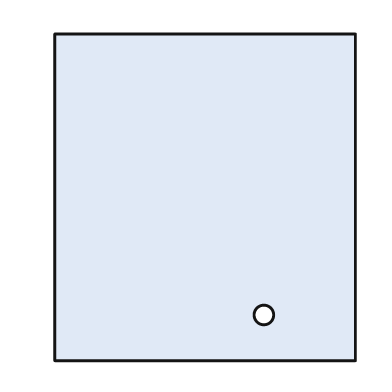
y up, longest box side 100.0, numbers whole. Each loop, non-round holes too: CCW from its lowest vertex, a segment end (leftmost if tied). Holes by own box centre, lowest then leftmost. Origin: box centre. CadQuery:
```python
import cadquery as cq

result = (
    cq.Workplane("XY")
    .moveTo(-46.0, -50.0)
    .lineTo(46.0, -50.0)
    .lineTo(46.0, 50.0)
    .lineTo(-46.0, 50.0)
    .close()
    .moveTo(18.0, -36.0)
    .circle(3.0)
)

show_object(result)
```